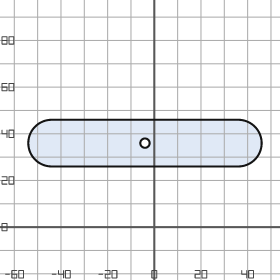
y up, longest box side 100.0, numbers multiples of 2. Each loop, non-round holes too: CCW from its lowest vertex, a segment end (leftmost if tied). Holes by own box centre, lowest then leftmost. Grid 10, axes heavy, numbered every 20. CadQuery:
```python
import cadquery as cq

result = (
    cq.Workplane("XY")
    .moveTo(-44.0, 26.0)
    .lineTo(36.0, 26.0)
    .threePointArc((46.0, 36.0), (36.0, 46.0))
    .lineTo(-44.0, 46.0)
    .threePointArc((-54.0, 36.0), (-44.0, 26.0))
    .close()
    .moveTo(-4.0, 36.0)
    .circle(2.0)
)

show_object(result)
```